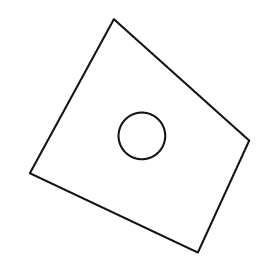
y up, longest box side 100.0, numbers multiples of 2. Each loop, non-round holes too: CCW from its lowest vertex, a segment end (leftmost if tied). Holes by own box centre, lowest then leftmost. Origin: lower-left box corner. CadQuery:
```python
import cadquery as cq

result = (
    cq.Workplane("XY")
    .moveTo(72.0, 0.0)
    .lineTo(94.0, 48.0)
    .lineTo(36.0, 100.0)
    .lineTo(0.0, 34.0)
    .close()
    .moveTo(48.0, 50.0)
    .circle(10.0)
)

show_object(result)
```